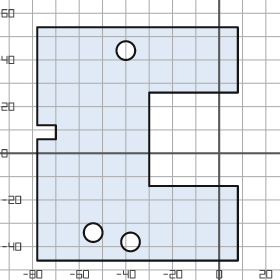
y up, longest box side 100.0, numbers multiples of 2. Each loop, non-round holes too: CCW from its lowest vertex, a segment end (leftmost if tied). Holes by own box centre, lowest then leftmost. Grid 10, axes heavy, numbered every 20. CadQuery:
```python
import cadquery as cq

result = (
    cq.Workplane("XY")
    .moveTo(-78.0, -46.0)
    .lineTo(8.0, -46.0)
    .lineTo(8.0, -14.0)
    .lineTo(-30.0, -14.0)
    .lineTo(-30.0, 26.0)
    .lineTo(8.0, 26.0)
    .lineTo(8.0, 54.0)
    .lineTo(-78.0, 54.0)
    .lineTo(-78.0, 12.0)
    .lineTo(-70.0, 12.0)
    .lineTo(-70.0, 6.0)
    .lineTo(-78.0, 6.0)
    .close()
    .moveTo(-38.0, -38.0)
    .circle(4.0)
    .moveTo(-54.0, -34.0)
    .circle(4.0)
    .moveTo(-40.0, 44.0)
    .circle(4.0)
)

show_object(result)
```